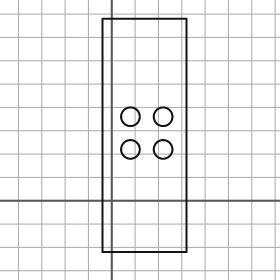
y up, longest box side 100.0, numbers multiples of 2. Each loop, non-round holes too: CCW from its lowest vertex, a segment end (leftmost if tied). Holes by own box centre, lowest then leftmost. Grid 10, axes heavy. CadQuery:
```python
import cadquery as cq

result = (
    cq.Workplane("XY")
    .moveTo(-4.0, -22.0)
    .lineTo(32.0, -22.0)
    .lineTo(32.0, 78.0)
    .lineTo(-4.0, 78.0)
    .close()
    .moveTo(8.0, 22.0)
    .circle(4.0)
    .moveTo(22.0, 22.0)
    .circle(4.0)
    .moveTo(8.0, 36.0)
    .circle(4.0)
    .moveTo(22.0, 36.0)
    .circle(4.0)
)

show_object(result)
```